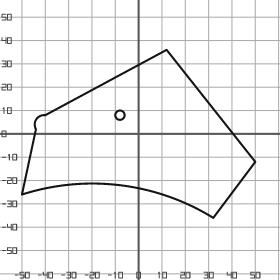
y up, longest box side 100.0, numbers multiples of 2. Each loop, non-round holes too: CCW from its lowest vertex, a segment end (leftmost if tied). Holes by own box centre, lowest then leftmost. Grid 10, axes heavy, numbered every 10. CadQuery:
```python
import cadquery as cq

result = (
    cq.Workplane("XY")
    .moveTo(32.0, -36.0)
    .lineTo(50.0, -12.0)
    .lineTo(12.0, 36.0)
    .lineTo(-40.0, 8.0)
    .threePointArc((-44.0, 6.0), (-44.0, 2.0))
    .lineTo(-50.0, -26.0)
    .threePointArc((-8.0, -22.0), (32.0, -36.0))
    .close()
    .moveTo(-8.0, 8.0)
    .circle(2.0)
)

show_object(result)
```